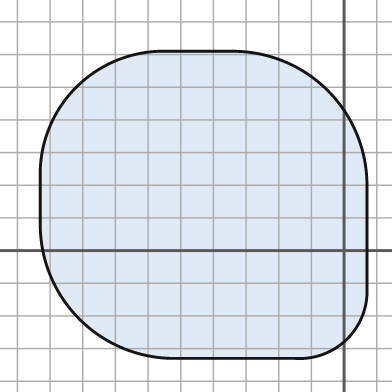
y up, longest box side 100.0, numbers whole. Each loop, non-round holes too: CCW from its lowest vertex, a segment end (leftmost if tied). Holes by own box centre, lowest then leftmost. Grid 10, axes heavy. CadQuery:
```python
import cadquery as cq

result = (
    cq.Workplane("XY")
    .moveTo(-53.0, -33.0)
    .lineTo(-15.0, -33.0)
    .threePointArc((1.0, -27.0), (7.0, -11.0))
    .lineTo(7.0, 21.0)
    .threePointArc((-5.0, 49.0), (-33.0, 61.0))
    .lineTo(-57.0, 61.0)
    .threePointArc((-82.0, 50.0), (-93.0, 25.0))
    .lineTo(-93.0, 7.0)
    .threePointArc((-81.0, -21.0), (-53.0, -33.0))
    .close()
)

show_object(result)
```